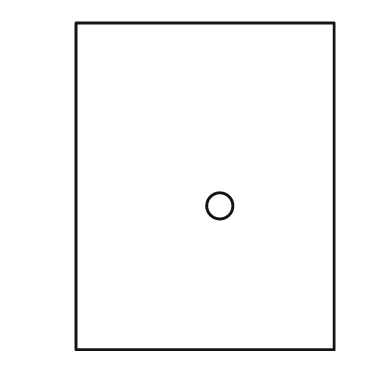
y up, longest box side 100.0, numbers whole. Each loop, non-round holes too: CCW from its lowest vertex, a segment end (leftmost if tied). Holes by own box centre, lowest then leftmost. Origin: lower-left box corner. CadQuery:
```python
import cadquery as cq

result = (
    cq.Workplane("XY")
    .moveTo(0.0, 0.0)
    .lineTo(79.0, 0.0)
    .lineTo(79.0, 100.0)
    .lineTo(0.0, 100.0)
    .close()
    .moveTo(44.0, 44.0)
    .circle(4.0)
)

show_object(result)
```